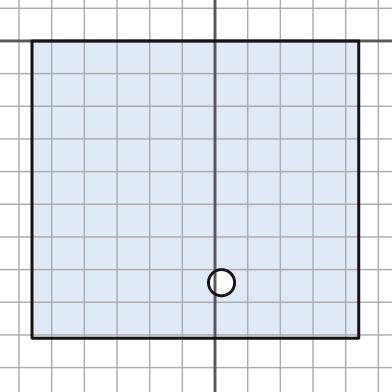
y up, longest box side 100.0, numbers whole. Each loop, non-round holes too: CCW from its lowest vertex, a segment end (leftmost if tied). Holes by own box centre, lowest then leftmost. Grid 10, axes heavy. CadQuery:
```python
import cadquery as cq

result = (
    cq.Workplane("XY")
    .moveTo(-56.0, -91.0)
    .lineTo(44.0, -91.0)
    .lineTo(44.0, 0.0)
    .lineTo(-56.0, 0.0)
    .close()
    .moveTo(2.0, -74.0)
    .circle(4.0)
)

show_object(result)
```